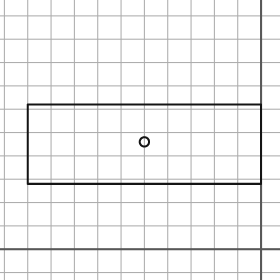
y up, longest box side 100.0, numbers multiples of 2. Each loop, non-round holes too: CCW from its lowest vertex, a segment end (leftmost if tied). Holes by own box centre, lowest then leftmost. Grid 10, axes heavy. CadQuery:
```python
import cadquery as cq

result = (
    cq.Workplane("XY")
    .moveTo(-100.0, 28.0)
    .lineTo(0.0, 28.0)
    .lineTo(0.0, 62.0)
    .lineTo(-100.0, 62.0)
    .close()
    .moveTo(-50.0, 46.0)
    .circle(2.0)
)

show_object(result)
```